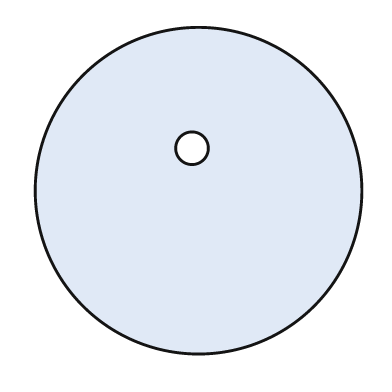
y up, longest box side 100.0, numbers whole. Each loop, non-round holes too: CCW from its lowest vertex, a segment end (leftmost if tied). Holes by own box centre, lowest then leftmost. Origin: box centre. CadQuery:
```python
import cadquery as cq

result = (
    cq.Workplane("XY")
    .moveTo(0.0, 0.0)
    .circle(50.0)
    .moveTo(-2.0, 13.0)
    .circle(5.0)
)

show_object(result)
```